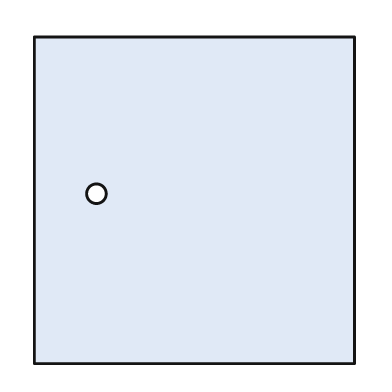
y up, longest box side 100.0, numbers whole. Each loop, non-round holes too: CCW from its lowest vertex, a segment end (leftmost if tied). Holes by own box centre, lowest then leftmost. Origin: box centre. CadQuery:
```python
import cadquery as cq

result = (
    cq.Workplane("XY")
    .moveTo(-49.0, -50.0)
    .lineTo(49.0, -50.0)
    .lineTo(49.0, 50.0)
    .lineTo(-49.0, 50.0)
    .close()
    .moveTo(-30.0, 2.0)
    .circle(3.0)
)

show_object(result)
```